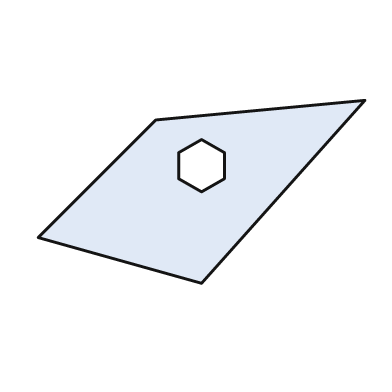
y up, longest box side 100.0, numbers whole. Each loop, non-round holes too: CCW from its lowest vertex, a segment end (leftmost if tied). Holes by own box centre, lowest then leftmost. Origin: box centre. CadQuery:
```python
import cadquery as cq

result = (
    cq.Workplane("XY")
    .moveTo(0.0, -28.0)
    .lineTo(50.0, 28.0)
    .lineTo(-14.0, 22.0)
    .lineTo(-50.0, -14.0)
    .close()
    .moveTo(0.0, 0.0)
    .lineTo(7.0, 4.0)
    .lineTo(7.0, 12.0)
    .lineTo(0.0, 16.0)
    .lineTo(-7.0, 12.0)
    .lineTo(-7.0, 4.0)
    .close()
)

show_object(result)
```